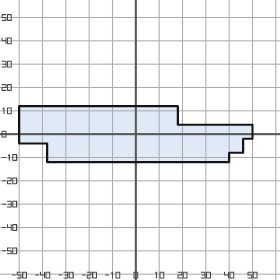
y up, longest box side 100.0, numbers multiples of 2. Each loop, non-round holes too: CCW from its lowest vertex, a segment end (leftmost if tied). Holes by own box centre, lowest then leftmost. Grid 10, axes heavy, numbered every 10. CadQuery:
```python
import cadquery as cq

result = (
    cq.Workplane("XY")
    .moveTo(-38.0, -12.0)
    .lineTo(40.0, -12.0)
    .lineTo(40.0, -8.0)
    .lineTo(46.0, -8.0)
    .lineTo(46.0, -2.0)
    .lineTo(50.0, -2.0)
    .lineTo(50.0, 4.0)
    .lineTo(18.0, 4.0)
    .lineTo(18.0, 12.0)
    .lineTo(-50.0, 12.0)
    .lineTo(-50.0, -4.0)
    .lineTo(-38.0, -4.0)
    .close()
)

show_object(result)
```